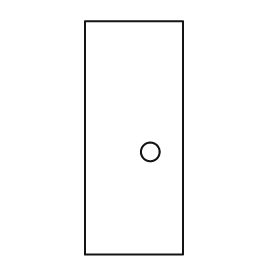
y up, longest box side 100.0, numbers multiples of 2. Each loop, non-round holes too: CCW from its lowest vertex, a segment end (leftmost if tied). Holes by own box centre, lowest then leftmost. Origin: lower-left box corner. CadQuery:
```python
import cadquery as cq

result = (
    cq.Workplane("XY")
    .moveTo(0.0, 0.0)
    .lineTo(42.0, 0.0)
    .lineTo(42.0, 100.0)
    .lineTo(0.0, 100.0)
    .close()
    .moveTo(28.0, 44.0)
    .circle(4.0)
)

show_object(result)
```